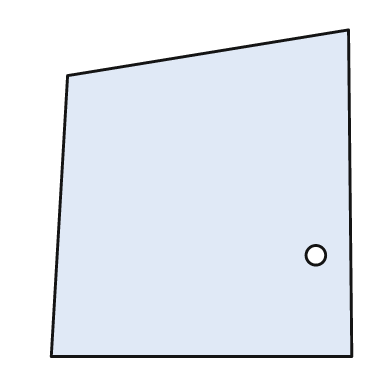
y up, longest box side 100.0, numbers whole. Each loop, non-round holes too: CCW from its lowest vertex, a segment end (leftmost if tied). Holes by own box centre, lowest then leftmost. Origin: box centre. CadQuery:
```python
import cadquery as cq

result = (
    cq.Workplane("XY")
    .moveTo(-46.0, -50.0)
    .lineTo(46.0, -50.0)
    .lineTo(45.0, 50.0)
    .lineTo(-41.0, 36.0)
    .close()
    .moveTo(35.0, -19.0)
    .circle(3.0)
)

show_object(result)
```